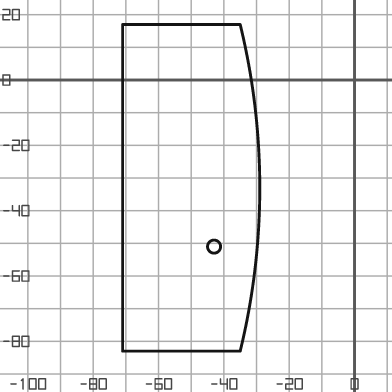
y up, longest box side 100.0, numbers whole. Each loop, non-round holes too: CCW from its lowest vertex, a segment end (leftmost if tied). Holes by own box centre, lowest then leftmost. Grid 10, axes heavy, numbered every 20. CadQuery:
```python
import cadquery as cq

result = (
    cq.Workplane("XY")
    .moveTo(-71.0, -83.0)
    .lineTo(-35.0, -83.0)
    .threePointArc((-29.0, -33.0), (-35.0, 17.0))
    .lineTo(-71.0, 17.0)
    .close()
    .moveTo(-43.0, -51.0)
    .circle(2.0)
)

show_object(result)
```